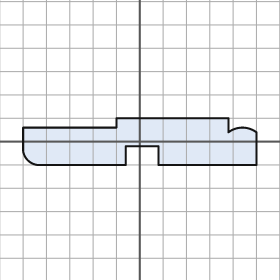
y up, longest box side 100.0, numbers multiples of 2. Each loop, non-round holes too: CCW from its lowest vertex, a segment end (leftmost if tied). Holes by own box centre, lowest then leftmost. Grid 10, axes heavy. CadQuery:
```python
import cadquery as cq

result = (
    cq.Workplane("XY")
    .moveTo(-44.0, -10.0)
    .lineTo(-6.0, -10.0)
    .lineTo(-6.0, -2.0)
    .lineTo(8.0, -2.0)
    .lineTo(8.0, -10.0)
    .lineTo(50.0, -10.0)
    .lineTo(50.0, 4.0)
    .threePointArc((44.0, 6.0), (38.0, 4.0))
    .lineTo(38.0, 10.0)
    .lineTo(-10.0, 10.0)
    .lineTo(-10.0, 6.0)
    .lineTo(-50.0, 6.0)
    .lineTo(-50.0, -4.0)
    .threePointArc((-48.0, -8.0), (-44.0, -10.0))
    .close()
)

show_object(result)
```